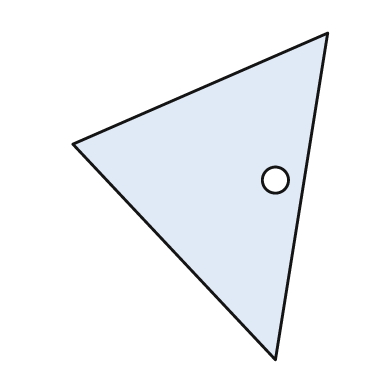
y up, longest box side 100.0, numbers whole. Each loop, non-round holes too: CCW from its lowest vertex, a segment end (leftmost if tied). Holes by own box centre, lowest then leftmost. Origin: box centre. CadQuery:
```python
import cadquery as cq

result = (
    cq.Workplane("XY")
    .moveTo(23.0, -50.0)
    .lineTo(39.0, 50.0)
    .lineTo(-39.0, 16.0)
    .close()
    .moveTo(23.0, 5.0)
    .circle(4.0)
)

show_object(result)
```